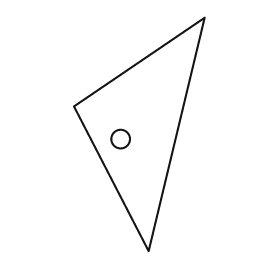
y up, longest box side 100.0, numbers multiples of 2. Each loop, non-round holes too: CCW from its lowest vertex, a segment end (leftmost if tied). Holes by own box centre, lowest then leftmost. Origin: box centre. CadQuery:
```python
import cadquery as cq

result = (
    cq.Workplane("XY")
    .moveTo(4.0, -50.0)
    .lineTo(28.0, 50.0)
    .lineTo(-28.0, 12.0)
    .close()
    .moveTo(-8.0, -2.0)
    .circle(4.0)
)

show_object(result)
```